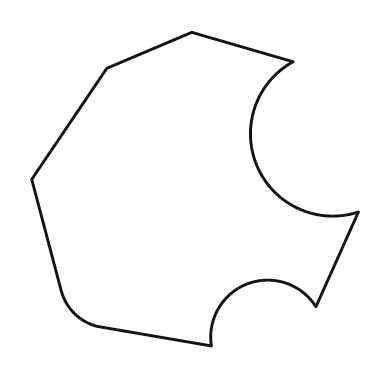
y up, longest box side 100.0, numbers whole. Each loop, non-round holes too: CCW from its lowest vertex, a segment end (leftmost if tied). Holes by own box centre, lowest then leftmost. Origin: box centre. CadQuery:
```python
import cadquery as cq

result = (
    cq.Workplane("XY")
    .moveTo(5.0, -48.0)
    .threePointArc((16.0, -29.0), (37.0, -36.0))
    .lineTo(50.0, -7.0)
    .threePointArc((19.0, 7.0), (30.0, 39.0))
    .lineTo(-1.0, 48.0)
    .lineTo(-27.0, 37.0)
    .lineTo(-50.0, 3.0)
    .lineTo(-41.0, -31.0)
    .threePointArc((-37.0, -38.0), (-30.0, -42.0))
    .close()
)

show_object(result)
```